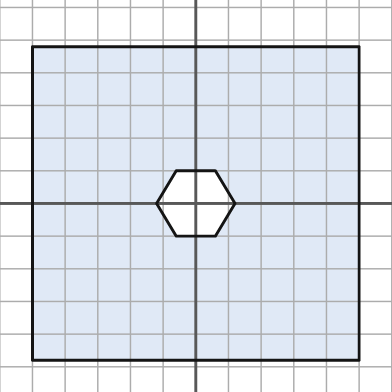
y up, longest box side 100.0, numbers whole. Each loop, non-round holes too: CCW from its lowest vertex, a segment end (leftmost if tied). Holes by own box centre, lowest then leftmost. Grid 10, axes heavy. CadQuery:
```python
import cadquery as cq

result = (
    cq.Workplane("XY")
    .moveTo(-50.0, -48.0)
    .lineTo(50.0, -48.0)
    .lineTo(50.0, 48.0)
    .lineTo(-50.0, 48.0)
    .close()
    .moveTo(-6.0, -10.0)
    .lineTo(6.0, -10.0)
    .lineTo(12.0, 0.0)
    .lineTo(6.0, 10.0)
    .lineTo(-6.0, 10.0)
    .lineTo(-12.0, 0.0)
    .close()
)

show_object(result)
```